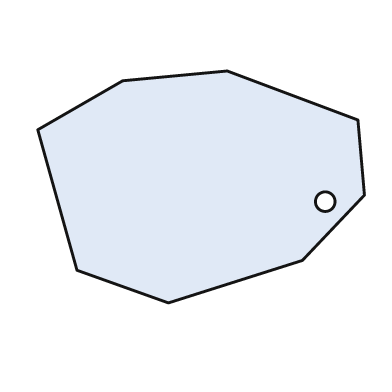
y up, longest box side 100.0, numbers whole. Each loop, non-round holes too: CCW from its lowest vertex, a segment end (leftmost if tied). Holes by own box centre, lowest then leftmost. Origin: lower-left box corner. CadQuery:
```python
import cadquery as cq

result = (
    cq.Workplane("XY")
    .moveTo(40.0, 0.0)
    .lineTo(81.0, 13.0)
    .lineTo(100.0, 33.0)
    .lineTo(98.0, 56.0)
    .lineTo(58.0, 71.0)
    .lineTo(26.0, 68.0)
    .lineTo(0.0, 53.0)
    .lineTo(12.0, 10.0)
    .close()
    .moveTo(88.0, 31.0)
    .circle(3.0)
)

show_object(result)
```